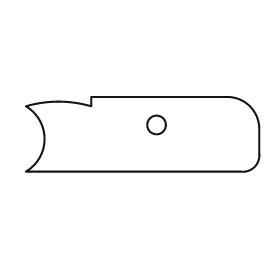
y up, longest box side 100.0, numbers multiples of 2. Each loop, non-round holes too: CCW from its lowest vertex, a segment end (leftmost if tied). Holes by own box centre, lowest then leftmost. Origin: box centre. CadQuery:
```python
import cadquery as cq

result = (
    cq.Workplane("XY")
    .moveTo(-50.0, -16.0)
    .lineTo(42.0, -16.0)
    .threePointArc((48.0, -14.0), (50.0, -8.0))
    .lineTo(50.0, 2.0)
    .threePointArc((46.0, 12.0), (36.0, 16.0))
    .lineTo(-22.0, 16.0)
    .lineTo(-22.0, 12.0)
    .threePointArc((-36.0, 14.0), (-50.0, 12.0))
    .threePointArc((-42.0, -2.0), (-50.0, -16.0))
    .close()
    .moveTo(6.0, 4.0)
    .circle(4.0)
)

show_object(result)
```